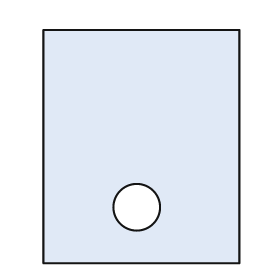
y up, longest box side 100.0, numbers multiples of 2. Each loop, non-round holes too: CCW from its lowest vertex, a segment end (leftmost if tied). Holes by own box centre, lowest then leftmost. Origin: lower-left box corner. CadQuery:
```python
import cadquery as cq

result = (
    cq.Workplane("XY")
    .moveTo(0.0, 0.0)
    .lineTo(84.0, 0.0)
    .lineTo(84.0, 100.0)
    .lineTo(0.0, 100.0)
    .close()
    .moveTo(40.0, 24.0)
    .circle(10.0)
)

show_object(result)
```